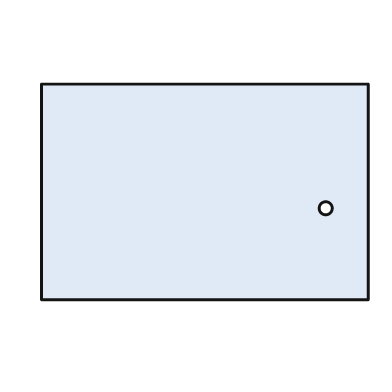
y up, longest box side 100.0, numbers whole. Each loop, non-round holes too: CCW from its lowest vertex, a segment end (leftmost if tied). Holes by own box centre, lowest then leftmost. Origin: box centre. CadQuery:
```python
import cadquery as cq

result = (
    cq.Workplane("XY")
    .moveTo(-50.0, -33.0)
    .lineTo(50.0, -33.0)
    .lineTo(50.0, 33.0)
    .lineTo(-50.0, 33.0)
    .close()
    .moveTo(37.0, -5.0)
    .circle(2.0)
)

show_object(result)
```